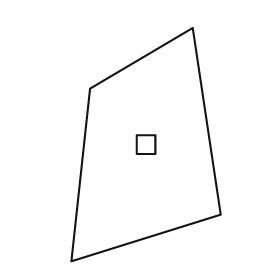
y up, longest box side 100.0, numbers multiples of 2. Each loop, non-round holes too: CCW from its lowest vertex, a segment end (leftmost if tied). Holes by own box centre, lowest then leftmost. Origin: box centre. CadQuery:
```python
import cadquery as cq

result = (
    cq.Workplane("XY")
    .moveTo(-32.0, -50.0)
    .lineTo(32.0, -30.0)
    .lineTo(20.0, 50.0)
    .lineTo(-24.0, 24.0)
    .close()
    .moveTo(-4.0, -4.0)
    .lineTo(4.0, -4.0)
    .lineTo(4.0, 4.0)
    .lineTo(-4.0, 4.0)
    .close()
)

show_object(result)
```